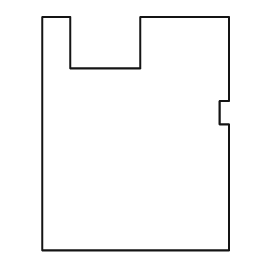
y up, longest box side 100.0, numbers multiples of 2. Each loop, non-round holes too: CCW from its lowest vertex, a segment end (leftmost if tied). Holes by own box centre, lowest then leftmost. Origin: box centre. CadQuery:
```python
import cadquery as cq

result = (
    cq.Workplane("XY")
    .moveTo(-40.0, -50.0)
    .lineTo(40.0, -50.0)
    .lineTo(40.0, 4.0)
    .lineTo(36.0, 4.0)
    .lineTo(36.0, 14.0)
    .lineTo(40.0, 14.0)
    .lineTo(40.0, 50.0)
    .lineTo(2.0, 50.0)
    .lineTo(2.0, 28.0)
    .lineTo(-28.0, 28.0)
    .lineTo(-28.0, 50.0)
    .lineTo(-40.0, 50.0)
    .close()
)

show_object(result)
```